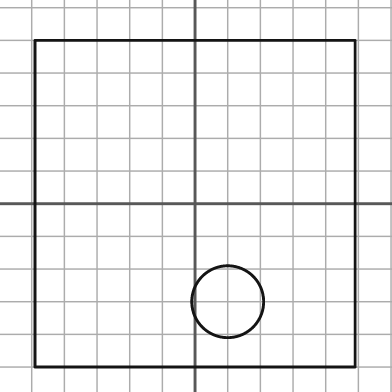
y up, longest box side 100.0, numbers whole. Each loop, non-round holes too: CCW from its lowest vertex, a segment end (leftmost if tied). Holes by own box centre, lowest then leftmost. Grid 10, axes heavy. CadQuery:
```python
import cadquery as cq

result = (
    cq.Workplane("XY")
    .moveTo(-49.0, -50.0)
    .lineTo(49.0, -50.0)
    .lineTo(49.0, 50.0)
    .lineTo(-49.0, 50.0)
    .close()
    .moveTo(10.0, -30.0)
    .circle(11.0)
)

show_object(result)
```